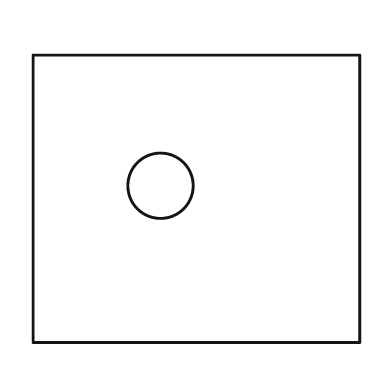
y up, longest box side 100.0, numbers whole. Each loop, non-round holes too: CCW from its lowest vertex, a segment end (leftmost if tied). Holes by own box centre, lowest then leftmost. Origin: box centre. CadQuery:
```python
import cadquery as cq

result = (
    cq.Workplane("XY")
    .moveTo(-50.0, -44.0)
    .lineTo(50.0, -44.0)
    .lineTo(50.0, 44.0)
    .lineTo(-50.0, 44.0)
    .close()
    .moveTo(-11.0, 4.0)
    .circle(10.0)
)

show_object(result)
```